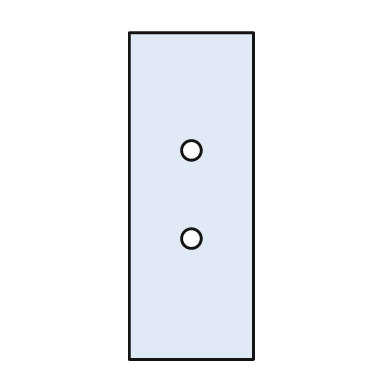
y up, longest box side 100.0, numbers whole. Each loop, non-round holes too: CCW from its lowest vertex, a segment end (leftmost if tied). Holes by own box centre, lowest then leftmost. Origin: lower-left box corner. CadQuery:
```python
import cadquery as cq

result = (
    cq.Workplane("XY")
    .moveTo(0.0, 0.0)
    .lineTo(38.0, 0.0)
    .lineTo(38.0, 100.0)
    .lineTo(0.0, 100.0)
    .close()
    .moveTo(19.0, 37.0)
    .circle(3.0)
    .moveTo(19.0, 64.0)
    .circle(3.0)
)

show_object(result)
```